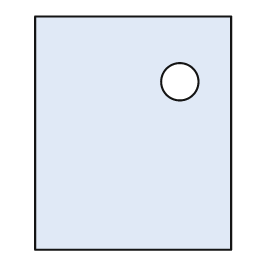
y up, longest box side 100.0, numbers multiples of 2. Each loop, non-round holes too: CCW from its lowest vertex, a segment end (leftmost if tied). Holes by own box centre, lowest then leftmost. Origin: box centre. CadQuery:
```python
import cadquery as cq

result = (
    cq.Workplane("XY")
    .moveTo(-42.0, -50.0)
    .lineTo(42.0, -50.0)
    .lineTo(42.0, 50.0)
    .lineTo(-42.0, 50.0)
    .close()
    .moveTo(20.0, 22.0)
    .circle(8.0)
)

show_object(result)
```